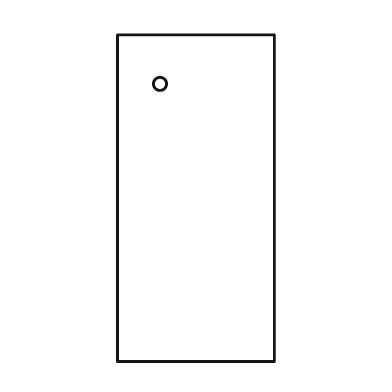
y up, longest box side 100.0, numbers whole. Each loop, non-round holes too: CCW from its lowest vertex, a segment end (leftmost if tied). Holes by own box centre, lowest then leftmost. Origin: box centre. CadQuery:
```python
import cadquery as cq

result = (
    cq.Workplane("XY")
    .moveTo(-24.0, -50.0)
    .lineTo(24.0, -50.0)
    .lineTo(24.0, 50.0)
    .lineTo(-24.0, 50.0)
    .close()
    .moveTo(-11.0, 35.0)
    .circle(2.0)
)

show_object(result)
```